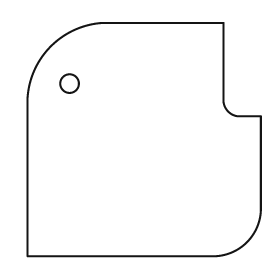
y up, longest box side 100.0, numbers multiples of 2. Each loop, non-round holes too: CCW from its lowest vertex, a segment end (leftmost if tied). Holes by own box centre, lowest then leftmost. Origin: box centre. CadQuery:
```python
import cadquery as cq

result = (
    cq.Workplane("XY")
    .moveTo(-50.0, -50.0)
    .lineTo(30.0, -50.0)
    .threePointArc((44.0, -44.0), (50.0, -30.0))
    .lineTo(50.0, 10.0)
    .lineTo(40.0, 10.0)
    .threePointArc((36.0, 12.0), (34.0, 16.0))
    .lineTo(34.0, 50.0)
    .lineTo(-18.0, 50.0)
    .threePointArc((-40.0, 40.0), (-50.0, 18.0))
    .close()
    .moveTo(-32.0, 24.0)
    .circle(4.0)
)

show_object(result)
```